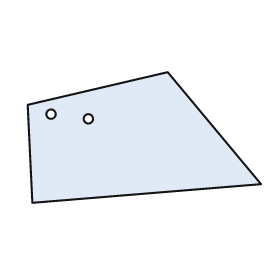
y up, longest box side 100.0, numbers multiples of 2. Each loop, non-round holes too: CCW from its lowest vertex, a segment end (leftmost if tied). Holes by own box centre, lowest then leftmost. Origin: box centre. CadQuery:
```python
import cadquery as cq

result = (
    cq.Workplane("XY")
    .moveTo(-48.0, -28.0)
    .lineTo(50.0, -20.0)
    .lineTo(10.0, 28.0)
    .lineTo(-50.0, 14.0)
    .close()
    .moveTo(-24.0, 8.0)
    .circle(2.0)
    .moveTo(-40.0, 10.0)
    .circle(2.0)
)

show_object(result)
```